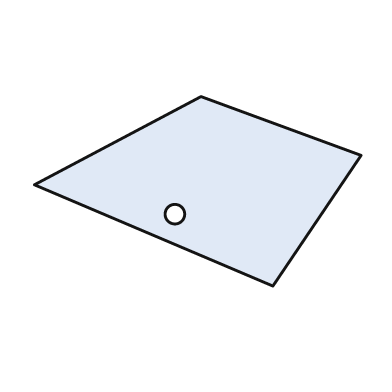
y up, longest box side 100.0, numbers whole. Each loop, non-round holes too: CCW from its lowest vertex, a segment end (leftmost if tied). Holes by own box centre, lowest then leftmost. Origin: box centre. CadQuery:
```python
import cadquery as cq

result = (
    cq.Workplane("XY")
    .moveTo(23.0, -29.0)
    .lineTo(50.0, 11.0)
    .lineTo(1.0, 29.0)
    .lineTo(-50.0, 2.0)
    .close()
    .moveTo(-7.0, -7.0)
    .circle(3.0)
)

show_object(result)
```